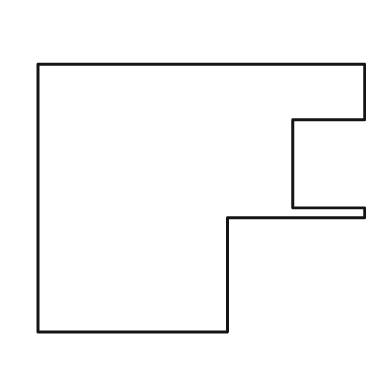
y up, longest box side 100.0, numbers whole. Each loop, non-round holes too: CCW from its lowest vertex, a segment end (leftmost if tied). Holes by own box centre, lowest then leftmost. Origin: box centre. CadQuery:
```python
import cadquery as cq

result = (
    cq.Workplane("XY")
    .moveTo(-50.0, -41.0)
    .lineTo(8.0, -41.0)
    .lineTo(8.0, -6.0)
    .lineTo(50.0, -6.0)
    .lineTo(50.0, -3.0)
    .lineTo(28.0, -3.0)
    .lineTo(28.0, 24.0)
    .lineTo(50.0, 24.0)
    .lineTo(50.0, 41.0)
    .lineTo(-50.0, 41.0)
    .close()
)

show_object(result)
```